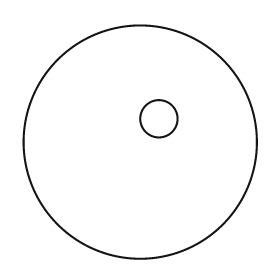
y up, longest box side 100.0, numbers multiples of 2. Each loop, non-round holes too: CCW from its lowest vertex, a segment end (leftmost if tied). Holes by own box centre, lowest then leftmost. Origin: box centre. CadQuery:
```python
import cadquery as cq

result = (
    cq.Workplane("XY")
    .moveTo(0.0, 0.0)
    .circle(50.0)
    .moveTo(8.0, 10.0)
    .circle(8.0)
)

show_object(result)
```